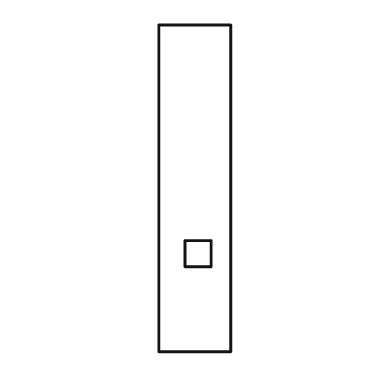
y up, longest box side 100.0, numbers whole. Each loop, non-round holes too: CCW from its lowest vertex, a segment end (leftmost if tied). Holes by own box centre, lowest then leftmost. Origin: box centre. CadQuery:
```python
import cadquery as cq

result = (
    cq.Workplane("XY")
    .moveTo(-11.0, -50.0)
    .lineTo(11.0, -50.0)
    .lineTo(11.0, 50.0)
    .lineTo(-11.0, 50.0)
    .close()
    .moveTo(-3.0, -24.0)
    .lineTo(5.0, -24.0)
    .lineTo(5.0, -16.0)
    .lineTo(-3.0, -16.0)
    .close()
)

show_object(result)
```